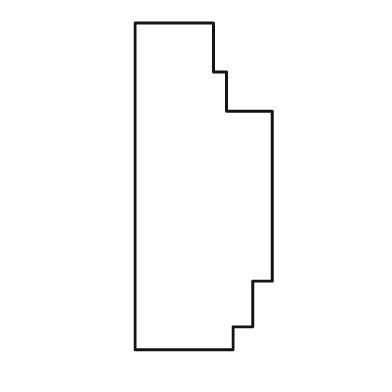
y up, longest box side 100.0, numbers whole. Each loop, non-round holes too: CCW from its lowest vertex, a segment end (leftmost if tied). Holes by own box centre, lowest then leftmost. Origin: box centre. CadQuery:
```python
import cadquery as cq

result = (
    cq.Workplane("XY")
    .moveTo(-21.0, -50.0)
    .lineTo(9.0, -50.0)
    .lineTo(9.0, -43.0)
    .lineTo(15.0, -43.0)
    .lineTo(15.0, -29.0)
    .lineTo(21.0, -29.0)
    .lineTo(21.0, 23.0)
    .lineTo(7.0, 23.0)
    .lineTo(7.0, 35.0)
    .lineTo(3.0, 35.0)
    .lineTo(3.0, 50.0)
    .lineTo(-21.0, 50.0)
    .close()
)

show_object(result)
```